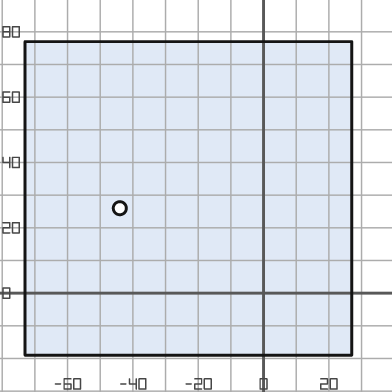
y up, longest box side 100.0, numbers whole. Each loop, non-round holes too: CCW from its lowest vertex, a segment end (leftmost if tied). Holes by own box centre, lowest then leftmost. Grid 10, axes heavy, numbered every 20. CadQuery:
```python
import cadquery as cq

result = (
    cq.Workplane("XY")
    .moveTo(-73.0, -19.0)
    .lineTo(27.0, -19.0)
    .lineTo(27.0, 77.0)
    .lineTo(-73.0, 77.0)
    .close()
    .moveTo(-44.0, 26.0)
    .circle(2.0)
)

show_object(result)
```